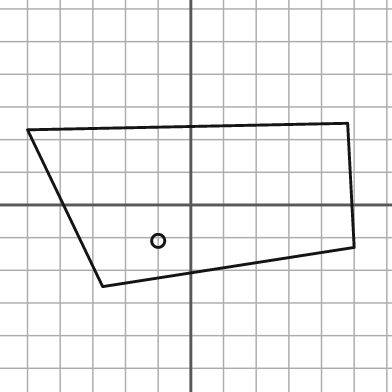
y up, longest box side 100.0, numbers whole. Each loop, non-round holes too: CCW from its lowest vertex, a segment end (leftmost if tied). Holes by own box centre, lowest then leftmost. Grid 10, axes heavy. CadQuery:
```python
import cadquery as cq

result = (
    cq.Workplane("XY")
    .moveTo(-27.0, -25.0)
    .lineTo(50.0, -13.0)
    .lineTo(48.0, 25.0)
    .lineTo(-50.0, 23.0)
    .close()
    .moveTo(-10.0, -11.0)
    .circle(2.0)
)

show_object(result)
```